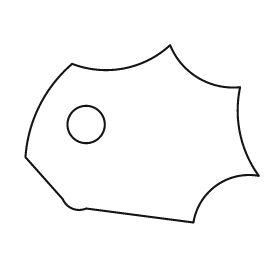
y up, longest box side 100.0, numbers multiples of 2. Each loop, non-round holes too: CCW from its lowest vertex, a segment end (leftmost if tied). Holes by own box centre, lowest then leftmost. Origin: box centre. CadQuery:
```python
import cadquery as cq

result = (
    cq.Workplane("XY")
    .moveTo(22.0, -38.0)
    .threePointArc((32.0, -22.0), (50.0, -18.0))
    .threePointArc((42.0, 0.0), (42.0, 20.0))
    .threePointArc((24.0, 24.0), (12.0, 38.0))
    .threePointArc((-8.0, 28.0), (-30.0, 30.0))
    .threePointArc((-44.0, 12.0), (-50.0, -10.0))
    .lineTo(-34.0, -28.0)
    .threePointArc((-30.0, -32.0), (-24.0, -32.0))
    .close()
    .moveTo(-24.0, 4.0)
    .circle(8.0)
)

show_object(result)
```